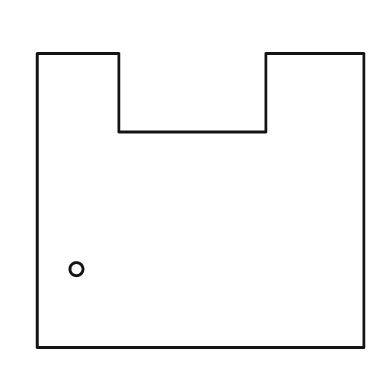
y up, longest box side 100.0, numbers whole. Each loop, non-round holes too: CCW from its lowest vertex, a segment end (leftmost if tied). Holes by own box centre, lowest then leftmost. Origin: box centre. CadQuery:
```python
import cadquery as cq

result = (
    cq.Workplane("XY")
    .moveTo(-50.0, -45.0)
    .lineTo(50.0, -45.0)
    .lineTo(50.0, 45.0)
    .lineTo(20.0, 45.0)
    .lineTo(20.0, 21.0)
    .lineTo(-25.0, 21.0)
    .lineTo(-25.0, 45.0)
    .lineTo(-50.0, 45.0)
    .close()
    .moveTo(-38.0, -21.0)
    .circle(2.0)
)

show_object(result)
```